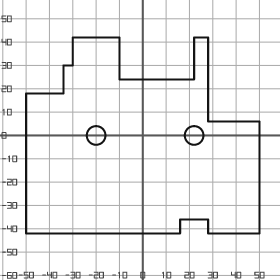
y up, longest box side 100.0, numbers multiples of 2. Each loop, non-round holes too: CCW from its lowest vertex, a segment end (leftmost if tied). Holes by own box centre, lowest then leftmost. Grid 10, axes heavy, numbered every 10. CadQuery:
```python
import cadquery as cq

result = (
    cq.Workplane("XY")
    .moveTo(-50.0, -42.0)
    .lineTo(16.0, -42.0)
    .lineTo(16.0, -36.0)
    .lineTo(28.0, -36.0)
    .lineTo(28.0, -42.0)
    .lineTo(50.0, -42.0)
    .lineTo(50.0, 6.0)
    .lineTo(28.0, 6.0)
    .lineTo(28.0, 42.0)
    .lineTo(22.0, 42.0)
    .lineTo(22.0, 24.0)
    .lineTo(-10.0, 24.0)
    .lineTo(-10.0, 42.0)
    .lineTo(-30.0, 42.0)
    .lineTo(-30.0, 30.0)
    .lineTo(-34.0, 30.0)
    .lineTo(-34.0, 18.0)
    .lineTo(-50.0, 18.0)
    .close()
    .moveTo(-20.0, 0.0)
    .circle(4.0)
    .moveTo(22.0, 0.0)
    .circle(4.0)
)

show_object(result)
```